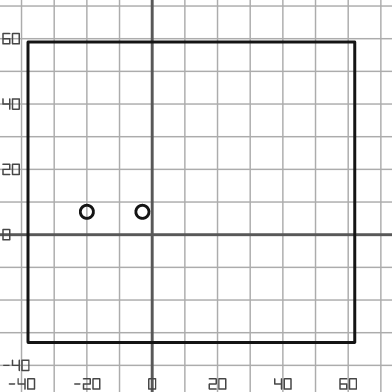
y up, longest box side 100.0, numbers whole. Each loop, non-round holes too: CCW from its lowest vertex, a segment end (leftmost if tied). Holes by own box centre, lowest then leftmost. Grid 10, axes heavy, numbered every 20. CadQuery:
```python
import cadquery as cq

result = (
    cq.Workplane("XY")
    .moveTo(-38.0, -33.0)
    .lineTo(62.0, -33.0)
    .lineTo(62.0, 59.0)
    .lineTo(-38.0, 59.0)
    .close()
    .moveTo(-20.0, 7.0)
    .circle(2.0)
    .moveTo(-3.0, 7.0)
    .circle(2.0)
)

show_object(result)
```